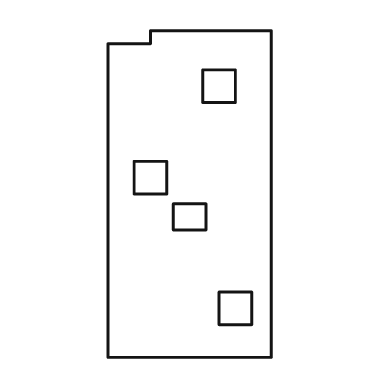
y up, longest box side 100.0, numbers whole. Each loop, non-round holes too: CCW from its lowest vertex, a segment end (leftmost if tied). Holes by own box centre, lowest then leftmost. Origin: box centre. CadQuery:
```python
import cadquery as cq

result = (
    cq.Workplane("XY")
    .moveTo(-25.0, -50.0)
    .lineTo(25.0, -50.0)
    .lineTo(25.0, 50.0)
    .lineTo(-12.0, 50.0)
    .lineTo(-12.0, 46.0)
    .lineTo(-25.0, 46.0)
    .close()
    .moveTo(9.0, -40.0)
    .lineTo(19.0, -40.0)
    .lineTo(19.0, -30.0)
    .lineTo(9.0, -30.0)
    .close()
    .moveTo(-5.0, -11.0)
    .lineTo(5.0, -11.0)
    .lineTo(5.0, -3.0)
    .lineTo(-5.0, -3.0)
    .close()
    .moveTo(-17.0, 0.0)
    .lineTo(-7.0, 0.0)
    .lineTo(-7.0, 10.0)
    .lineTo(-17.0, 10.0)
    .close()
    .moveTo(4.0, 28.0)
    .lineTo(14.0, 28.0)
    .lineTo(14.0, 38.0)
    .lineTo(4.0, 38.0)
    .close()
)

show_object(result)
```